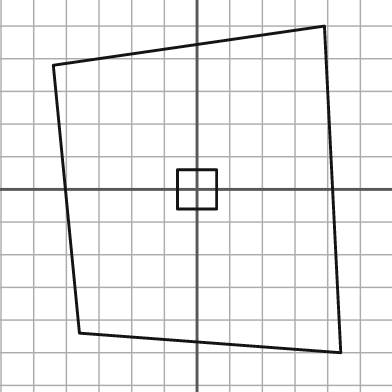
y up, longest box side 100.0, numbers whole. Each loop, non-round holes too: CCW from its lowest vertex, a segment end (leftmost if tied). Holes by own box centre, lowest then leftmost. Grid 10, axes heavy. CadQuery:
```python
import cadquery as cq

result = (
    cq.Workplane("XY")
    .moveTo(44.0, -50.0)
    .lineTo(39.0, 50.0)
    .lineTo(-44.0, 38.0)
    .lineTo(-36.0, -44.0)
    .close()
    .moveTo(-6.0, -6.0)
    .lineTo(6.0, -6.0)
    .lineTo(6.0, 6.0)
    .lineTo(-6.0, 6.0)
    .close()
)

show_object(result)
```